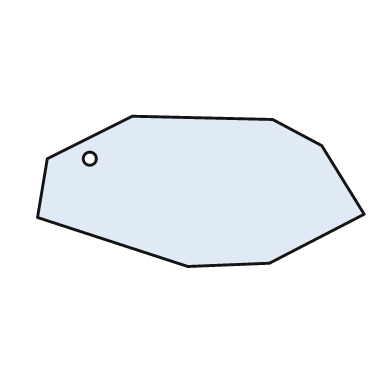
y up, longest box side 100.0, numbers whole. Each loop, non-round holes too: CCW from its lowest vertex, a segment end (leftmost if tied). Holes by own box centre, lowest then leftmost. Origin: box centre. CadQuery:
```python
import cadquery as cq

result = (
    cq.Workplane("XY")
    .moveTo(-4.0, -23.0)
    .lineTo(21.0, -22.0)
    .lineTo(50.0, -7.0)
    .lineTo(37.0, 14.0)
    .lineTo(22.0, 22.0)
    .lineTo(-21.0, 23.0)
    .lineTo(-47.0, 10.0)
    .lineTo(-50.0, -8.0)
    .close()
    .moveTo(-34.0, 10.0)
    .circle(2.0)
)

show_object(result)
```